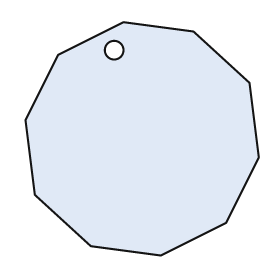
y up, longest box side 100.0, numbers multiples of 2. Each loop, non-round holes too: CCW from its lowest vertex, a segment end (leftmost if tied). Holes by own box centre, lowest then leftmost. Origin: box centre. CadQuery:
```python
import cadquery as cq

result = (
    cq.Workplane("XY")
    .moveTo(8.0, -50.0)
    .lineTo(36.0, -36.0)
    .lineTo(50.0, -8.0)
    .lineTo(46.0, 24.0)
    .lineTo(22.0, 46.0)
    .lineTo(-8.0, 50.0)
    .lineTo(-36.0, 36.0)
    .lineTo(-50.0, 8.0)
    .lineTo(-46.0, -24.0)
    .lineTo(-22.0, -46.0)
    .close()
    .moveTo(-12.0, 38.0)
    .circle(4.0)
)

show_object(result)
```